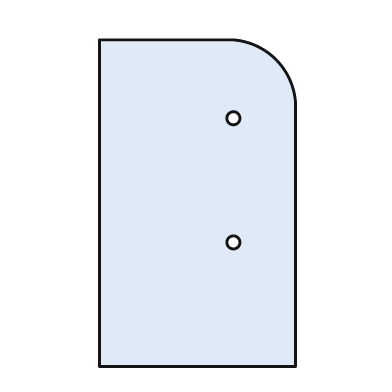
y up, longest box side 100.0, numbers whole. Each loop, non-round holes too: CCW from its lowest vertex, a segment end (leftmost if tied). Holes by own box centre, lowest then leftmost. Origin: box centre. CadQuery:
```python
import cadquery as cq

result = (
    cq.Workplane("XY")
    .moveTo(-30.0, -50.0)
    .lineTo(30.0, -50.0)
    .lineTo(30.0, 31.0)
    .threePointArc((24.0, 44.0), (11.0, 50.0))
    .lineTo(-30.0, 50.0)
    .close()
    .moveTo(11.0, -12.0)
    .circle(2.0)
    .moveTo(11.0, 26.0)
    .circle(2.0)
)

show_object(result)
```